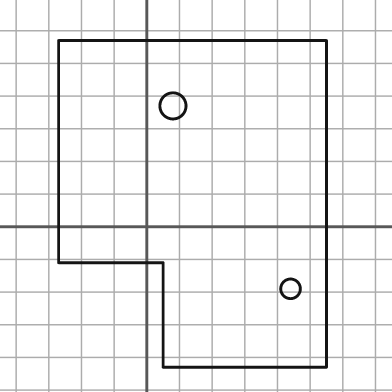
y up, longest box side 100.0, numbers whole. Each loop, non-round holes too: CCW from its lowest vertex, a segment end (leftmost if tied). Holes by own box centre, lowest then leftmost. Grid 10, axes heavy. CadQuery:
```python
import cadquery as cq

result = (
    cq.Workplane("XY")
    .moveTo(5.0, -43.0)
    .lineTo(55.0, -43.0)
    .lineTo(55.0, 57.0)
    .lineTo(-27.0, 57.0)
    .lineTo(-27.0, -11.0)
    .lineTo(5.0, -11.0)
    .close()
    .moveTo(44.0, -19.0)
    .circle(3.0)
    .moveTo(8.0, 37.0)
    .circle(4.0)
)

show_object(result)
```